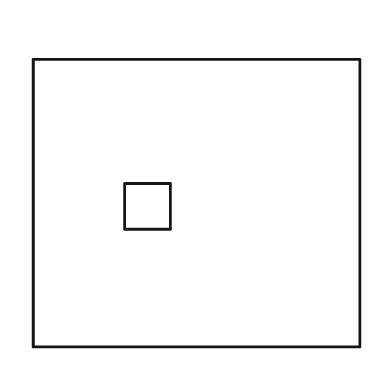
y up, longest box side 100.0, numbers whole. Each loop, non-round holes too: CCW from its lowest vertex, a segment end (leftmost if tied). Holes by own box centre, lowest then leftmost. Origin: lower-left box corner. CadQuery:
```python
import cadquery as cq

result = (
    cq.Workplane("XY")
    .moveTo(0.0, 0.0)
    .lineTo(100.0, 0.0)
    .lineTo(100.0, 88.0)
    .lineTo(0.0, 88.0)
    .close()
    .moveTo(28.0, 36.0)
    .lineTo(42.0, 36.0)
    .lineTo(42.0, 50.0)
    .lineTo(28.0, 50.0)
    .close()
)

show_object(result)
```